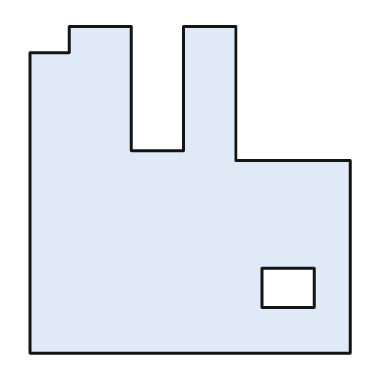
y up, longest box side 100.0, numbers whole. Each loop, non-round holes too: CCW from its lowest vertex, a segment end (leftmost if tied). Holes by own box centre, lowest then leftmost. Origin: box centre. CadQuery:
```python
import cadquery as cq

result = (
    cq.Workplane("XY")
    .moveTo(-49.0, -50.0)
    .lineTo(49.0, -50.0)
    .lineTo(49.0, 9.0)
    .lineTo(14.0, 9.0)
    .lineTo(14.0, 50.0)
    .lineTo(-2.0, 50.0)
    .lineTo(-2.0, 12.0)
    .lineTo(-18.0, 12.0)
    .lineTo(-18.0, 50.0)
    .lineTo(-37.0, 50.0)
    .lineTo(-37.0, 42.0)
    .lineTo(-49.0, 42.0)
    .close()
    .moveTo(22.0, -36.0)
    .lineTo(38.0, -36.0)
    .lineTo(38.0, -24.0)
    .lineTo(22.0, -24.0)
    .close()
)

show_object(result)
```